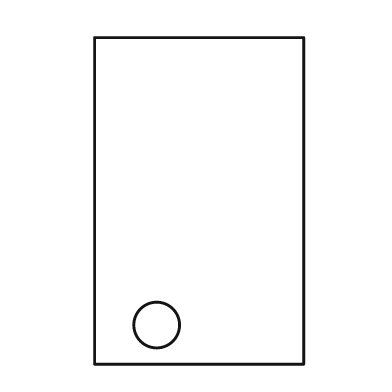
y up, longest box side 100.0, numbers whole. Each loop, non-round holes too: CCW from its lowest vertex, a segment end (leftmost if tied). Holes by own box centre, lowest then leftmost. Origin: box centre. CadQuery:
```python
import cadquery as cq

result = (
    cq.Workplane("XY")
    .moveTo(-32.0, -50.0)
    .lineTo(32.0, -50.0)
    .lineTo(32.0, 50.0)
    .lineTo(-32.0, 50.0)
    .close()
    .moveTo(-13.0, -38.0)
    .circle(7.0)
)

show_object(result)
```